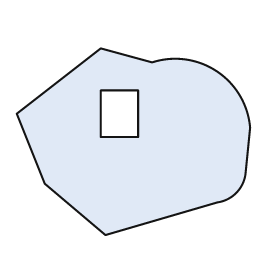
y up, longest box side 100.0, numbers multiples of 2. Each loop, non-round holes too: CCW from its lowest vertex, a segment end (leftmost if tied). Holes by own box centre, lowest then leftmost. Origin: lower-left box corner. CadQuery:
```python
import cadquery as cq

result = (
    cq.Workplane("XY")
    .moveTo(38.0, 0.0)
    .lineTo(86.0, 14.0)
    .threePointArc((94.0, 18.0), (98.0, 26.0))
    .lineTo(100.0, 46.0)
    .threePointArc((86.0, 70.0), (58.0, 74.0))
    .lineTo(36.0, 80.0)
    .lineTo(0.0, 52.0)
    .lineTo(12.0, 22.0)
    .close()
    .moveTo(36.0, 42.0)
    .lineTo(52.0, 42.0)
    .lineTo(52.0, 62.0)
    .lineTo(36.0, 62.0)
    .close()
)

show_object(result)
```